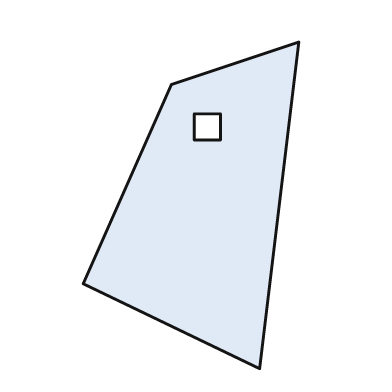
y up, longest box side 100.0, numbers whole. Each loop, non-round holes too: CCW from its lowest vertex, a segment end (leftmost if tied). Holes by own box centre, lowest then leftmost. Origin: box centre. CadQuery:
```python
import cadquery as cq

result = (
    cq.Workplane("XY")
    .moveTo(21.0, -50.0)
    .lineTo(33.0, 50.0)
    .lineTo(-6.0, 37.0)
    .lineTo(-33.0, -24.0)
    .close()
    .moveTo(1.0, 20.0)
    .lineTo(9.0, 20.0)
    .lineTo(9.0, 28.0)
    .lineTo(1.0, 28.0)
    .close()
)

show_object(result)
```